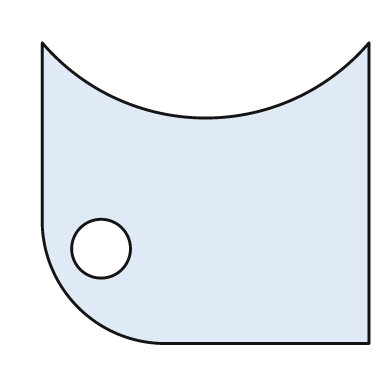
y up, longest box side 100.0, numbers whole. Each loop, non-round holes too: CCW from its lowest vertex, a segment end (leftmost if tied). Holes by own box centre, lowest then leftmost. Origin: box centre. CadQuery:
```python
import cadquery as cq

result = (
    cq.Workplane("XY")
    .moveTo(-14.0, -46.0)
    .lineTo(50.0, -46.0)
    .lineTo(50.0, 46.0)
    .threePointArc((0.0, 23.0), (-50.0, 46.0))
    .lineTo(-50.0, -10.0)
    .threePointArc((-39.0, -35.0), (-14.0, -46.0))
    .close()
    .moveTo(-32.0, -17.0)
    .circle(9.0)
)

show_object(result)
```